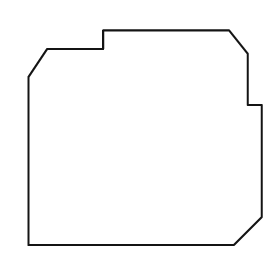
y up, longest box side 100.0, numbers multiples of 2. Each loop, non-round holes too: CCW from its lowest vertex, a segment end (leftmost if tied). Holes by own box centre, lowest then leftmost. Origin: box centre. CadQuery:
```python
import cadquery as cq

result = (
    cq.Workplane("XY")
    .moveTo(-50.0, -46.0)
    .lineTo(38.0, -46.0)
    .lineTo(50.0, -34.0)
    .lineTo(50.0, 14.0)
    .lineTo(44.0, 14.0)
    .lineTo(44.0, 36.0)
    .lineTo(36.0, 46.0)
    .lineTo(-18.0, 46.0)
    .lineTo(-18.0, 38.0)
    .lineTo(-42.0, 38.0)
    .lineTo(-50.0, 26.0)
    .close()
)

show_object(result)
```